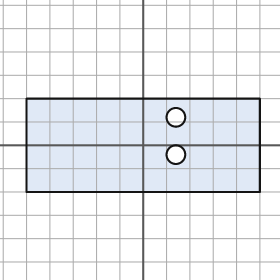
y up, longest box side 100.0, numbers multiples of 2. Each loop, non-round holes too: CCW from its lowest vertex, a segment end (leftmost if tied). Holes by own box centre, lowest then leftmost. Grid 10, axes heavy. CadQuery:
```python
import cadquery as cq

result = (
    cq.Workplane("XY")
    .moveTo(-50.0, -20.0)
    .lineTo(50.0, -20.0)
    .lineTo(50.0, 20.0)
    .lineTo(-50.0, 20.0)
    .close()
    .moveTo(14.0, -4.0)
    .circle(4.0)
    .moveTo(14.0, 12.0)
    .circle(4.0)
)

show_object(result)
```